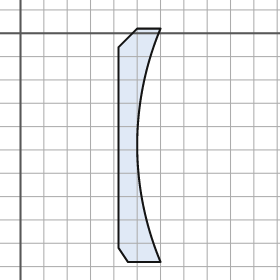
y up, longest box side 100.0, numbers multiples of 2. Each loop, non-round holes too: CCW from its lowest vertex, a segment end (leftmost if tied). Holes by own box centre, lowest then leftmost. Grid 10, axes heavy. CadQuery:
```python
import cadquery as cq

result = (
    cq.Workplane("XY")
    .moveTo(46.0, -98.0)
    .lineTo(60.0, -98.0)
    .threePointArc((50.0, -48.0), (60.0, 2.0))
    .lineTo(50.0, 2.0)
    .lineTo(42.0, -6.0)
    .lineTo(42.0, -92.0)
    .close()
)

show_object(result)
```